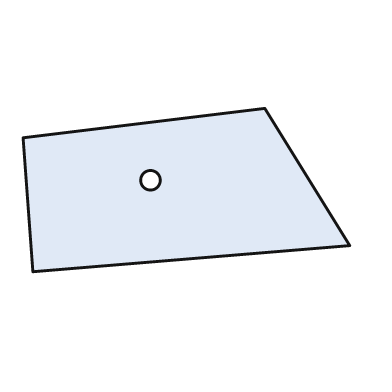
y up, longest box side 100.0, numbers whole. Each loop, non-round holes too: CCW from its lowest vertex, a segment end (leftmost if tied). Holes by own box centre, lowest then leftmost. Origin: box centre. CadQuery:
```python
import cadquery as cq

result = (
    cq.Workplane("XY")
    .moveTo(-47.0, -25.0)
    .lineTo(50.0, -17.0)
    .lineTo(24.0, 25.0)
    .lineTo(-50.0, 16.0)
    .close()
    .moveTo(-11.0, 3.0)
    .circle(3.0)
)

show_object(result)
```